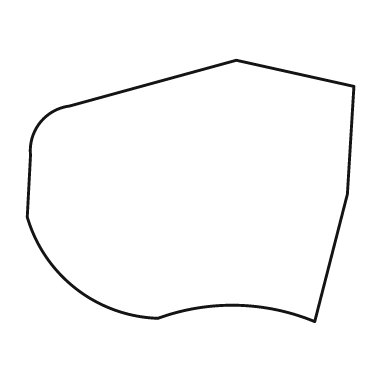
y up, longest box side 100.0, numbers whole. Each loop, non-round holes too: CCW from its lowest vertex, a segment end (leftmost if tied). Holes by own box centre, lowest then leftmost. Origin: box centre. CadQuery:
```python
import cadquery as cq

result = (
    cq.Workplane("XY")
    .moveTo(38.0, -40.0)
    .lineTo(48.0, -1.0)
    .lineTo(50.0, 32.0)
    .lineTo(14.0, 40.0)
    .lineTo(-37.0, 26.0)
    .threePointArc((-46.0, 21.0), (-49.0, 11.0))
    .lineTo(-50.0, -8.0)
    .threePointArc((-35.0, -30.0), (-10.0, -39.0))
    .threePointArc((14.0, -35.0), (38.0, -40.0))
    .close()
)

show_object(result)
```